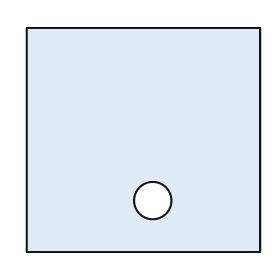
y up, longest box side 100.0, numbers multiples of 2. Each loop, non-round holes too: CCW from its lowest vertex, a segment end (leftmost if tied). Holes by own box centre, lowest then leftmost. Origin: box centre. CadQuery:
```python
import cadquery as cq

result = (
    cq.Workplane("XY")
    .moveTo(-50.0, -48.0)
    .lineTo(50.0, -48.0)
    .lineTo(50.0, 48.0)
    .lineTo(-50.0, 48.0)
    .close()
    .moveTo(4.0, -26.0)
    .circle(8.0)
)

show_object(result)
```